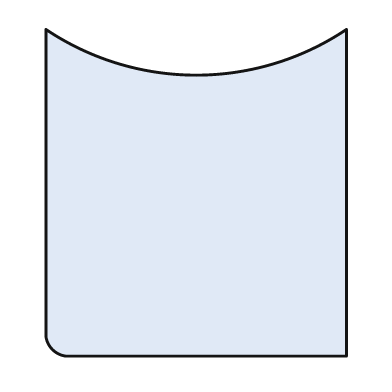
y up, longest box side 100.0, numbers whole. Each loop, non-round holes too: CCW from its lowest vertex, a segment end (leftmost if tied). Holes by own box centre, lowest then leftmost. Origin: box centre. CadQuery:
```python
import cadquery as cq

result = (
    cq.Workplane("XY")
    .moveTo(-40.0, -50.0)
    .lineTo(46.0, -50.0)
    .lineTo(46.0, 50.0)
    .threePointArc((0.0, 36.0), (-46.0, 50.0))
    .lineTo(-46.0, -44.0)
    .threePointArc((-44.0, -48.0), (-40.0, -50.0))
    .close()
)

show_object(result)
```